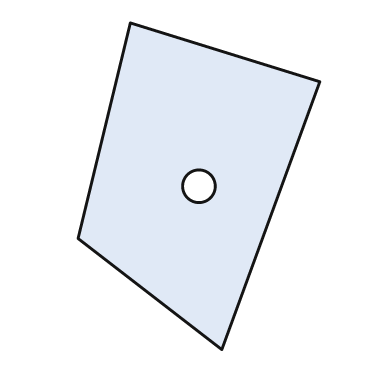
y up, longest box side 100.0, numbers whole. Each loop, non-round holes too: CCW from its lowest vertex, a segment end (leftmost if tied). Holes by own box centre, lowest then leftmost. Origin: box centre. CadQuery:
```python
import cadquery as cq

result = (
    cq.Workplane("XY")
    .moveTo(7.0, -50.0)
    .lineTo(37.0, 32.0)
    .lineTo(-21.0, 50.0)
    .lineTo(-37.0, -16.0)
    .close()
    .moveTo(0.0, 0.0)
    .circle(5.0)
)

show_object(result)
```